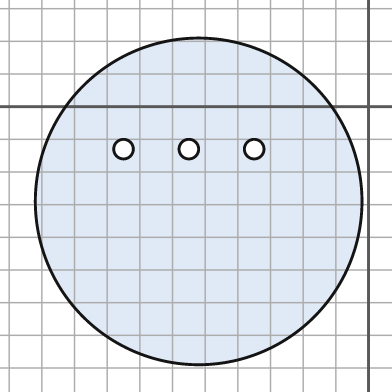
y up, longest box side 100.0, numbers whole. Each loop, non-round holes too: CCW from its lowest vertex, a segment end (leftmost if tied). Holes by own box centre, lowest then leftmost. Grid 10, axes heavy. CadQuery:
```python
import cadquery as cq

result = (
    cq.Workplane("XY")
    .moveTo(-52.0, -29.0)
    .circle(50.0)
    .moveTo(-75.0, -13.0)
    .circle(3.0)
    .moveTo(-55.0, -13.0)
    .circle(3.0)
    .moveTo(-35.0, -13.0)
    .circle(3.0)
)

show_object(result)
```